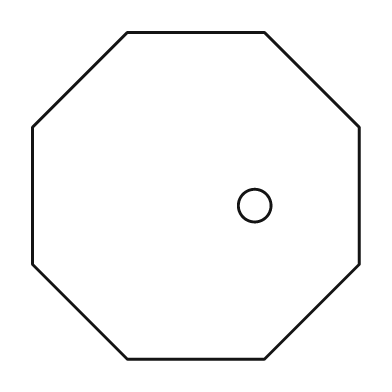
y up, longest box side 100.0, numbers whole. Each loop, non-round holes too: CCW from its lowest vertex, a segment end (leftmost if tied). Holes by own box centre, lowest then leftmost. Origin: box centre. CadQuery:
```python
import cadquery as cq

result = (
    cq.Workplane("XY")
    .moveTo(-21.0, -50.0)
    .lineTo(21.0, -50.0)
    .lineTo(50.0, -21.0)
    .lineTo(50.0, 21.0)
    .lineTo(21.0, 50.0)
    .lineTo(-21.0, 50.0)
    .lineTo(-50.0, 21.0)
    .lineTo(-50.0, -21.0)
    .close()
    .moveTo(18.0, -3.0)
    .circle(5.0)
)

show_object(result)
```